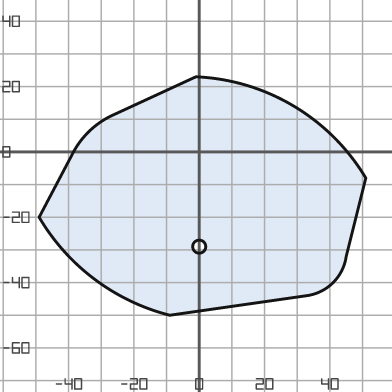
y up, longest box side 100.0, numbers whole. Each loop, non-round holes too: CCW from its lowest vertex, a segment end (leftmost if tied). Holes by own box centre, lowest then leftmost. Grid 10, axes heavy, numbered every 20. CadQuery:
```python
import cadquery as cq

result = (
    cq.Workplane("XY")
    .moveTo(-9.0, -50.0)
    .lineTo(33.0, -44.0)
    .threePointArc((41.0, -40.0), (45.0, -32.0))
    .lineTo(51.0, -8.0)
    .threePointArc((29.0, 14.0), (-1.0, 23.0))
    .lineTo(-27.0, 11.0)
    .threePointArc((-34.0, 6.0), (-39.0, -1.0))
    .lineTo(-49.0, -20.0)
    .threePointArc((-32.0, -39.0), (-9.0, -50.0))
    .close()
    .moveTo(0.0, -29.0)
    .circle(2.0)
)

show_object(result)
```